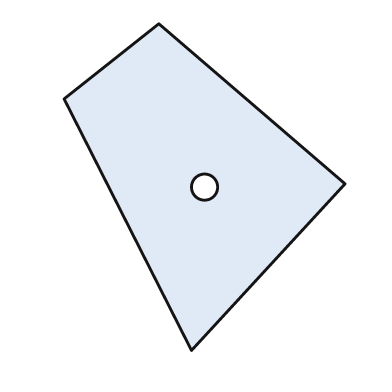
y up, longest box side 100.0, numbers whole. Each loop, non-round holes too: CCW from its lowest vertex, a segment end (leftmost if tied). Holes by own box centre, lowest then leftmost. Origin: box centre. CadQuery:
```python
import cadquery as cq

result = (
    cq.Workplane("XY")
    .moveTo(-4.0, -50.0)
    .lineTo(43.0, 1.0)
    .lineTo(-14.0, 50.0)
    .lineTo(-43.0, 27.0)
    .close()
    .moveTo(0.0, 0.0)
    .circle(4.0)
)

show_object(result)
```